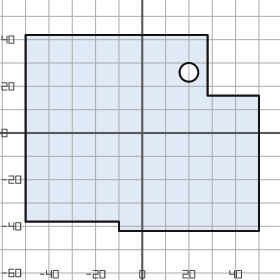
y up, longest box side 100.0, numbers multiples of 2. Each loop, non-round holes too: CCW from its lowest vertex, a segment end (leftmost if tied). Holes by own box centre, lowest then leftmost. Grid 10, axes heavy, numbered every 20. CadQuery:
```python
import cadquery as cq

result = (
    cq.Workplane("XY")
    .moveTo(-10.0, -42.0)
    .lineTo(50.0, -42.0)
    .lineTo(50.0, 16.0)
    .lineTo(28.0, 16.0)
    .lineTo(28.0, 42.0)
    .lineTo(-50.0, 42.0)
    .lineTo(-50.0, -38.0)
    .lineTo(-10.0, -38.0)
    .close()
    .moveTo(20.0, 26.0)
    .circle(4.0)
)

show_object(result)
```